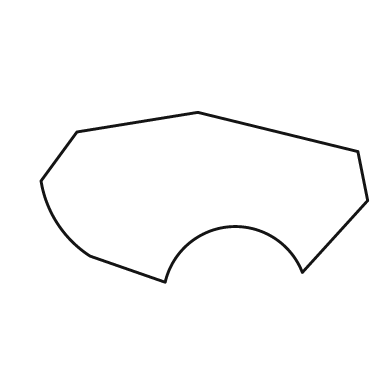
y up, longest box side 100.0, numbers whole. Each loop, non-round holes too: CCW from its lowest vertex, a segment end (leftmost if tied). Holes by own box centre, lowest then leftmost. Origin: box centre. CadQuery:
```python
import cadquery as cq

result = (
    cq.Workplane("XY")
    .moveTo(-12.0, -26.0)
    .threePointArc((8.0, -9.0), (30.0, -23.0))
    .lineTo(50.0, -1.0)
    .lineTo(47.0, 14.0)
    .lineTo(-2.0, 26.0)
    .lineTo(-39.0, 20.0)
    .lineTo(-50.0, 5.0)
    .threePointArc((-45.0, -8.0), (-35.0, -18.0))
    .close()
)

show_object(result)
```